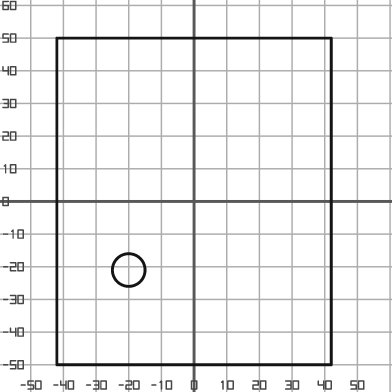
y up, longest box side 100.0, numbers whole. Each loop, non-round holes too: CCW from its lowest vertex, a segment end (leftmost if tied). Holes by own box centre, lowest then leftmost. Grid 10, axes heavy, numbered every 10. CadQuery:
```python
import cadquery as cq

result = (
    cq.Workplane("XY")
    .moveTo(-42.0, -50.0)
    .lineTo(42.0, -50.0)
    .lineTo(42.0, 50.0)
    .lineTo(-42.0, 50.0)
    .close()
    .moveTo(-20.0, -21.0)
    .circle(5.0)
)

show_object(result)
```